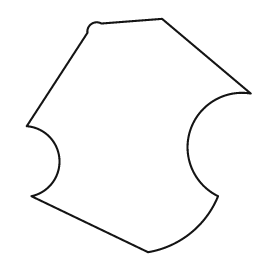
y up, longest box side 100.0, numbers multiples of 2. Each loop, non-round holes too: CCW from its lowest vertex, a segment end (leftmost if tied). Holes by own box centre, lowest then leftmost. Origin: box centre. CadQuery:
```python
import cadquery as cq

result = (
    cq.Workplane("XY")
    .moveTo(4.0, -50.0)
    .threePointArc((22.0, -42.0), (34.0, -26.0))
    .threePointArc((22.0, 2.0), (48.0, 18.0))
    .lineTo(10.0, 50.0)
    .lineTo(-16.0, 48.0)
    .threePointArc((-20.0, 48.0), (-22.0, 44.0))
    .lineTo(-48.0, 4.0)
    .threePointArc((-34.0, -10.0), (-46.0, -26.0))
    .close()
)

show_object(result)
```